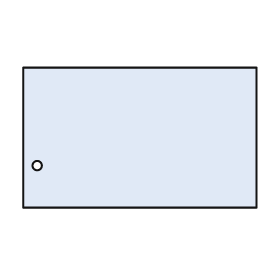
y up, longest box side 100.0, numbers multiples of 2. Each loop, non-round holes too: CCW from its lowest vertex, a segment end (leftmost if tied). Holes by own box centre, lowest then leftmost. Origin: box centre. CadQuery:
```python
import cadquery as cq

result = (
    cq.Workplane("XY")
    .moveTo(-50.0, -30.0)
    .lineTo(50.0, -30.0)
    .lineTo(50.0, 30.0)
    .lineTo(-50.0, 30.0)
    .close()
    .moveTo(-44.0, -12.0)
    .circle(2.0)
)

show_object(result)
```